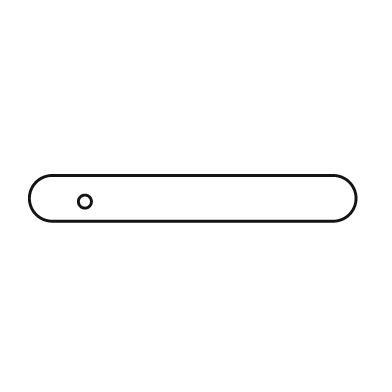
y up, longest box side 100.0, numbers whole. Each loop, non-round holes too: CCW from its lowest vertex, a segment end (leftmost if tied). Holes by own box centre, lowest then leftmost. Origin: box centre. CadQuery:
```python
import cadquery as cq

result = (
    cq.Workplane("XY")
    .moveTo(-43.0, -7.0)
    .lineTo(43.0, -7.0)
    .threePointArc((50.0, 0.0), (43.0, 7.0))
    .lineTo(-43.0, 7.0)
    .threePointArc((-50.0, 0.0), (-43.0, -7.0))
    .close()
    .moveTo(-33.0, -1.0)
    .circle(2.0)
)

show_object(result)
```